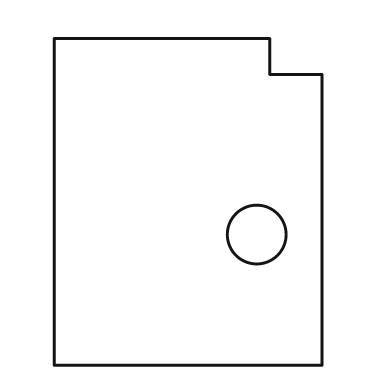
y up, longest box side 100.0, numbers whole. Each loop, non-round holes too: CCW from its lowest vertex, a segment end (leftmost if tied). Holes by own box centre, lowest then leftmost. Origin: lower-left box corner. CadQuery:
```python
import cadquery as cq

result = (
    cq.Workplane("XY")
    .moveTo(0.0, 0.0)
    .lineTo(82.0, 0.0)
    .lineTo(82.0, 89.0)
    .lineTo(66.0, 89.0)
    .lineTo(66.0, 100.0)
    .lineTo(0.0, 100.0)
    .close()
    .moveTo(62.0, 40.0)
    .circle(9.0)
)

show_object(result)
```